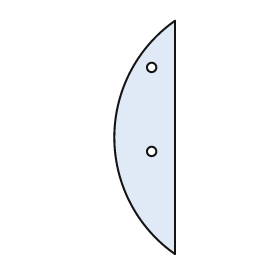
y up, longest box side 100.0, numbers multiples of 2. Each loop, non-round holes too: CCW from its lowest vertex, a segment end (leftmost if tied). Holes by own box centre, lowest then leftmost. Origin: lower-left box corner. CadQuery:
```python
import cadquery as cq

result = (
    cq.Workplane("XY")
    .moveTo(26.0, 0.0)
    .lineTo(26.0, 100.0)
    .threePointArc((0.0, 50.0), (26.0, 0.0))
    .close()
    .moveTo(16.0, 44.0)
    .circle(2.0)
    .moveTo(16.0, 80.0)
    .circle(2.0)
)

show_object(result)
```